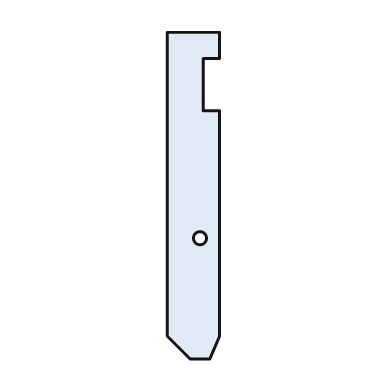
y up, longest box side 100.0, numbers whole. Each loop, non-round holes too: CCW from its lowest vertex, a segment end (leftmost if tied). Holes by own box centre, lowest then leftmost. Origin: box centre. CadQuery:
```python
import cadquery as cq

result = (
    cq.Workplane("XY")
    .moveTo(-1.0, -50.0)
    .lineTo(5.0, -50.0)
    .lineTo(8.0, -43.0)
    .lineTo(8.0, 26.0)
    .lineTo(3.0, 26.0)
    .lineTo(3.0, 42.0)
    .lineTo(8.0, 42.0)
    .lineTo(8.0, 50.0)
    .lineTo(-8.0, 50.0)
    .lineTo(-8.0, -43.0)
    .close()
    .moveTo(2.0, -13.0)
    .circle(2.0)
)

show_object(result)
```